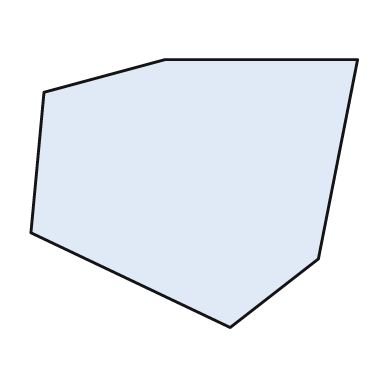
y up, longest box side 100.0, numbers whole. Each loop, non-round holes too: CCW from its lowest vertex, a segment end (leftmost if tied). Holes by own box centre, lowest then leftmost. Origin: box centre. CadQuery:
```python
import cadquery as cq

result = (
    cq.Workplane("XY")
    .moveTo(11.0, -41.0)
    .lineTo(38.0, -20.0)
    .lineTo(50.0, 41.0)
    .lineTo(-9.0, 41.0)
    .lineTo(-46.0, 31.0)
    .lineTo(-50.0, -12.0)
    .close()
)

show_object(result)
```